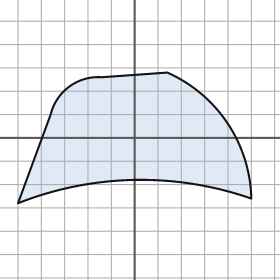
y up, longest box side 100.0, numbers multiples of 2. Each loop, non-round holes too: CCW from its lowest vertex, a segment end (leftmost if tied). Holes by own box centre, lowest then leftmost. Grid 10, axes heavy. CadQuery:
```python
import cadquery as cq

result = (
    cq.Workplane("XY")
    .moveTo(-50.0, -28.0)
    .threePointArc((0.0, -18.0), (50.0, -26.0))
    .threePointArc((40.0, 6.0), (14.0, 28.0))
    .lineTo(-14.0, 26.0)
    .threePointArc((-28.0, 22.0), (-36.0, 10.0))
    .close()
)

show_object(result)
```